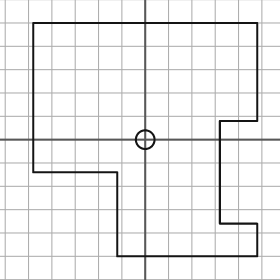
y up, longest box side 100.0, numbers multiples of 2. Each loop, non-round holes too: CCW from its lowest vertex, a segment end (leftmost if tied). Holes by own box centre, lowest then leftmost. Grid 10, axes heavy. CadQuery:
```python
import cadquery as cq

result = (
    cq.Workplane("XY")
    .moveTo(-12.0, -50.0)
    .lineTo(48.0, -50.0)
    .lineTo(48.0, -36.0)
    .lineTo(32.0, -36.0)
    .lineTo(32.0, 8.0)
    .lineTo(48.0, 8.0)
    .lineTo(48.0, 50.0)
    .lineTo(-48.0, 50.0)
    .lineTo(-48.0, -14.0)
    .lineTo(-12.0, -14.0)
    .close()
    .moveTo(0.0, 0.0)
    .circle(4.0)
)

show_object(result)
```